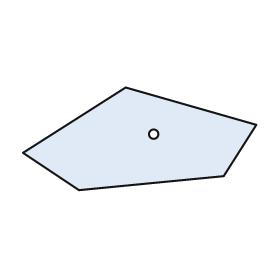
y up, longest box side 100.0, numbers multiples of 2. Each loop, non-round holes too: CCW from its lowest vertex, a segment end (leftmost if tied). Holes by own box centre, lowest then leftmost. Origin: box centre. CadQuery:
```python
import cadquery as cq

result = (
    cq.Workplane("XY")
    .moveTo(-26.0, -22.0)
    .lineTo(36.0, -16.0)
    .lineTo(50.0, 6.0)
    .lineTo(-6.0, 22.0)
    .lineTo(-50.0, -6.0)
    .close()
    .moveTo(6.0, 2.0)
    .circle(2.0)
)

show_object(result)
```